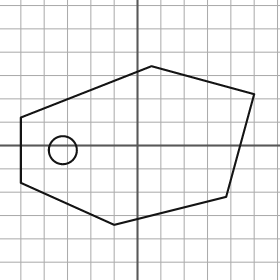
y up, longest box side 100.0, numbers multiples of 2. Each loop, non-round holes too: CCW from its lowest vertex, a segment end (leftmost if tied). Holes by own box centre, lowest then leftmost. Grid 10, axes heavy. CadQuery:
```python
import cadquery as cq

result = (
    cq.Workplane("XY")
    .moveTo(-10.0, -34.0)
    .lineTo(38.0, -22.0)
    .lineTo(50.0, 22.0)
    .lineTo(6.0, 34.0)
    .lineTo(-50.0, 12.0)
    .lineTo(-50.0, -16.0)
    .close()
    .moveTo(-32.0, -2.0)
    .circle(6.0)
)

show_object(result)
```